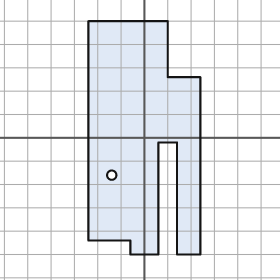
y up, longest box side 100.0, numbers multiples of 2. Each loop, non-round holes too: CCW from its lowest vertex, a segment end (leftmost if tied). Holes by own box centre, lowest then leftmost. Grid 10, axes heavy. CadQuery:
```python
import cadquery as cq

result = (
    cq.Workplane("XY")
    .moveTo(-6.0, -50.0)
    .lineTo(6.0, -50.0)
    .lineTo(6.0, -2.0)
    .lineTo(14.0, -2.0)
    .lineTo(14.0, -50.0)
    .lineTo(24.0, -50.0)
    .lineTo(24.0, 26.0)
    .lineTo(10.0, 26.0)
    .lineTo(10.0, 50.0)
    .lineTo(-24.0, 50.0)
    .lineTo(-24.0, -44.0)
    .lineTo(-6.0, -44.0)
    .close()
    .moveTo(-14.0, -16.0)
    .circle(2.0)
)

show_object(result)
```